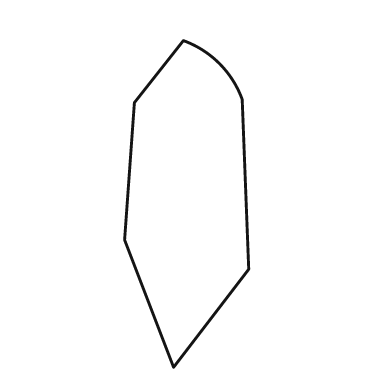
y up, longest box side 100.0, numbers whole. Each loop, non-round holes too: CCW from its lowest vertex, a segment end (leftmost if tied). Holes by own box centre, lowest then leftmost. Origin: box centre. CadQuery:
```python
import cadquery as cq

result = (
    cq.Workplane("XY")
    .moveTo(-4.0, -50.0)
    .lineTo(19.0, -20.0)
    .lineTo(17.0, 32.0)
    .threePointArc((10.0, 43.0), (-1.0, 50.0))
    .lineTo(-16.0, 31.0)
    .lineTo(-19.0, -11.0)
    .close()
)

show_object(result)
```